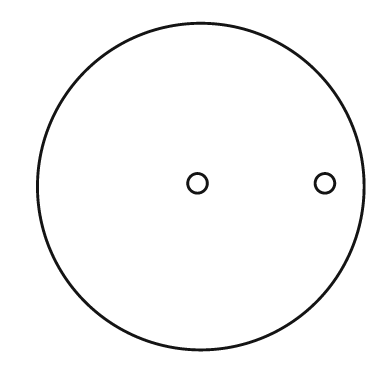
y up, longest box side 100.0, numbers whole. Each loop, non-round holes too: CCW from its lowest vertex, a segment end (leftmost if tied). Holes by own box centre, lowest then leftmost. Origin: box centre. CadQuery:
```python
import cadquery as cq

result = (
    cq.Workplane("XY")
    .moveTo(0.0, 0.0)
    .circle(50.0)
    .moveTo(-1.0, 1.0)
    .circle(3.0)
    .moveTo(38.0, 1.0)
    .circle(3.0)
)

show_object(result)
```